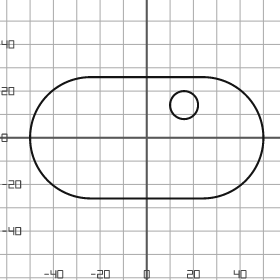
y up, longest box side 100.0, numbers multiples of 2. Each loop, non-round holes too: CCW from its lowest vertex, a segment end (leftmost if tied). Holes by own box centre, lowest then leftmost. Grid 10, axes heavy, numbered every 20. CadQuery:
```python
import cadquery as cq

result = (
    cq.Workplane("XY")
    .moveTo(-24.0, -26.0)
    .lineTo(24.0, -26.0)
    .threePointArc((50.0, 0.0), (24.0, 26.0))
    .lineTo(-24.0, 26.0)
    .threePointArc((-50.0, 0.0), (-24.0, -26.0))
    .close()
    .moveTo(16.0, 14.0)
    .circle(6.0)
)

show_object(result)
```